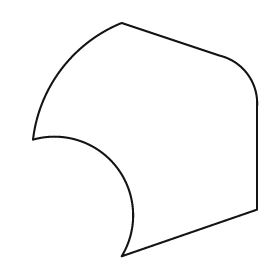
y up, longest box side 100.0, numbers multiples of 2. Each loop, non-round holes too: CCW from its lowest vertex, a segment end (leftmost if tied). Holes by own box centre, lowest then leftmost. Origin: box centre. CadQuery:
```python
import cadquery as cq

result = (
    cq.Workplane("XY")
    .moveTo(-10.0, -50.0)
    .lineTo(48.0, -30.0)
    .lineTo(48.0, 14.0)
    .threePointArc((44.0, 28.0), (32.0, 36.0))
    .lineTo(-10.0, 50.0)
    .threePointArc((-36.0, 30.0), (-48.0, 0.0))
    .threePointArc((-12.0, -12.0), (-10.0, -50.0))
    .close()
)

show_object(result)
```